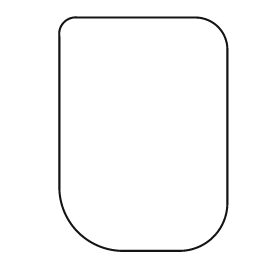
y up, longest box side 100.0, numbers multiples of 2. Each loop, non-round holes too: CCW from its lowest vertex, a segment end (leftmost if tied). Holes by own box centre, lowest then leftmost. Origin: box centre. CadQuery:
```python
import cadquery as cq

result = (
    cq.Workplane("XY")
    .moveTo(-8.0, -50.0)
    .lineTo(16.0, -50.0)
    .threePointArc((30.0, -44.0), (36.0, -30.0))
    .lineTo(36.0, 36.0)
    .threePointArc((32.0, 46.0), (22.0, 50.0))
    .lineTo(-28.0, 50.0)
    .threePointArc((-34.0, 48.0), (-36.0, 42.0))
    .lineTo(-36.0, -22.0)
    .threePointArc((-28.0, -42.0), (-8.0, -50.0))
    .close()
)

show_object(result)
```